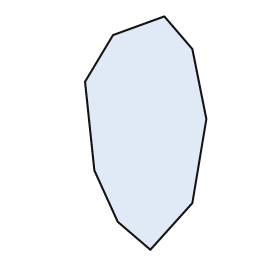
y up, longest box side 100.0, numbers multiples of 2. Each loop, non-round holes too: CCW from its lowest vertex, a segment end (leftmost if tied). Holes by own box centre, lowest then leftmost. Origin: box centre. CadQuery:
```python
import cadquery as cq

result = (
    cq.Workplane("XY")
    .moveTo(2.0, -50.0)
    .lineTo(20.0, -30.0)
    .lineTo(26.0, 6.0)
    .lineTo(20.0, 36.0)
    .lineTo(8.0, 50.0)
    .lineTo(-14.0, 42.0)
    .lineTo(-26.0, 22.0)
    .lineTo(-22.0, -16.0)
    .lineTo(-12.0, -38.0)
    .close()
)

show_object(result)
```